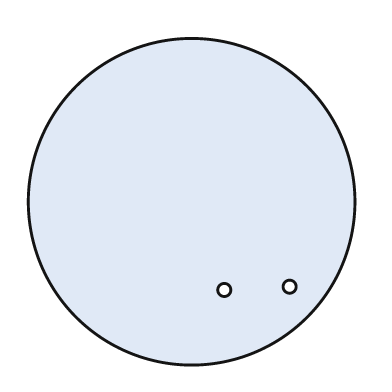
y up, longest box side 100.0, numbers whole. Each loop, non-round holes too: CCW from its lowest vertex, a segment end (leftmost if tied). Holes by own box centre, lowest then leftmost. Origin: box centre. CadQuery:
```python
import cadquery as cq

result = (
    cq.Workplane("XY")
    .moveTo(0.0, 0.0)
    .circle(50.0)
    .moveTo(10.0, -27.0)
    .circle(2.0)
    .moveTo(30.0, -26.0)
    .circle(2.0)
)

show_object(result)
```